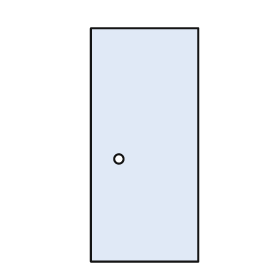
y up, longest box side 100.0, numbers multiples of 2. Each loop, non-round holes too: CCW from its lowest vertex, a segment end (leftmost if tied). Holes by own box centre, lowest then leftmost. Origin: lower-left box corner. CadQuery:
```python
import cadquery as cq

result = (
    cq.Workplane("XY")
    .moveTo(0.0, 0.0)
    .lineTo(46.0, 0.0)
    .lineTo(46.0, 100.0)
    .lineTo(0.0, 100.0)
    .close()
    .moveTo(12.0, 44.0)
    .circle(2.0)
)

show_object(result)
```